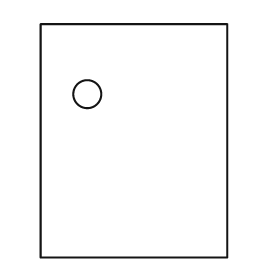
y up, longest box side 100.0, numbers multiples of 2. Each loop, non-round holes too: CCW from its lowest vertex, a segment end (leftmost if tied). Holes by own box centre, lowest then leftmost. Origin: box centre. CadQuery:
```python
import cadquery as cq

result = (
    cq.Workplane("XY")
    .moveTo(-40.0, -50.0)
    .lineTo(40.0, -50.0)
    .lineTo(40.0, 50.0)
    .lineTo(-40.0, 50.0)
    .close()
    .moveTo(-20.0, 20.0)
    .circle(6.0)
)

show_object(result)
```